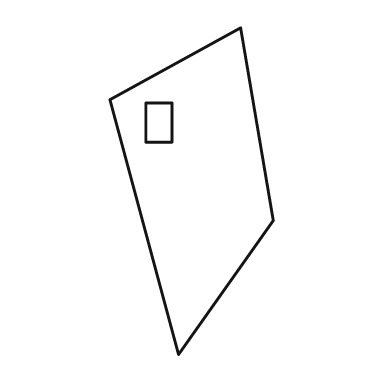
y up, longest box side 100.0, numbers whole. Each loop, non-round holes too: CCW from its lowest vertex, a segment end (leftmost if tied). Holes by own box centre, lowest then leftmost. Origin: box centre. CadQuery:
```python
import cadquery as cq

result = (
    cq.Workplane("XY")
    .moveTo(-4.0, -50.0)
    .lineTo(25.0, -9.0)
    .lineTo(15.0, 50.0)
    .lineTo(-25.0, 28.0)
    .close()
    .moveTo(-14.0, 15.0)
    .lineTo(-6.0, 15.0)
    .lineTo(-6.0, 27.0)
    .lineTo(-14.0, 27.0)
    .close()
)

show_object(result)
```